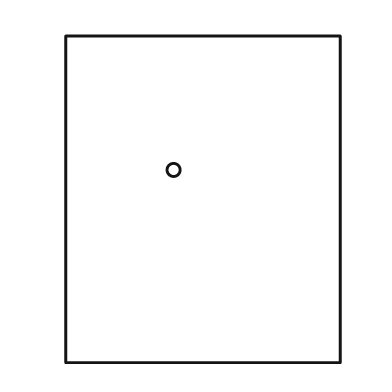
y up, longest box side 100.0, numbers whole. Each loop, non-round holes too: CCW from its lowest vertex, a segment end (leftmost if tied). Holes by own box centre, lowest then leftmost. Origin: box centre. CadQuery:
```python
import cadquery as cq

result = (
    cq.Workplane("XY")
    .moveTo(-42.0, -50.0)
    .lineTo(42.0, -50.0)
    .lineTo(42.0, 50.0)
    .lineTo(-42.0, 50.0)
    .close()
    .moveTo(-9.0, 9.0)
    .circle(2.0)
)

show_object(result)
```